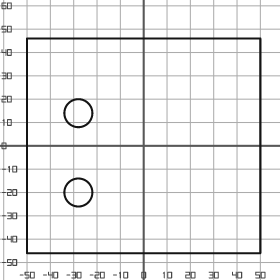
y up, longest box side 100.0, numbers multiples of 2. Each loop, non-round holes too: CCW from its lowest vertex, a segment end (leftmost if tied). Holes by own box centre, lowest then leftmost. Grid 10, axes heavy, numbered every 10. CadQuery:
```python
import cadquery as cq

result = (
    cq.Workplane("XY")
    .moveTo(-50.0, -46.0)
    .lineTo(50.0, -46.0)
    .lineTo(50.0, 46.0)
    .lineTo(-50.0, 46.0)
    .close()
    .moveTo(-28.0, -20.0)
    .circle(6.0)
    .moveTo(-28.0, 14.0)
    .circle(6.0)
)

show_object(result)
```